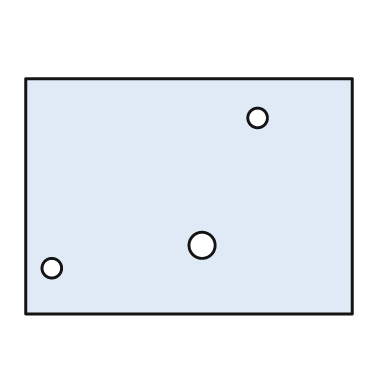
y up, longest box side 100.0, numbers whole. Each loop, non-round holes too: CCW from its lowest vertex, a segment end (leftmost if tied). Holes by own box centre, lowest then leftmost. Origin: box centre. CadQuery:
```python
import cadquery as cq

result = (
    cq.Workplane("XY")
    .moveTo(-50.0, -36.0)
    .lineTo(50.0, -36.0)
    .lineTo(50.0, 36.0)
    .lineTo(-50.0, 36.0)
    .close()
    .moveTo(-42.0, -22.0)
    .circle(3.0)
    .moveTo(4.0, -15.0)
    .circle(4.0)
    .moveTo(21.0, 24.0)
    .circle(3.0)
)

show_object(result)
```